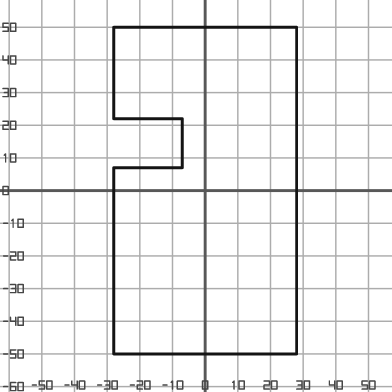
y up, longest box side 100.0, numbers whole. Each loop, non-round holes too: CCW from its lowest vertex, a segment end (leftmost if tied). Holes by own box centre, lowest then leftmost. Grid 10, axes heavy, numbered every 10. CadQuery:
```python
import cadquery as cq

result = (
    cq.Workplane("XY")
    .moveTo(-28.0, -50.0)
    .lineTo(28.0, -50.0)
    .lineTo(28.0, 50.0)
    .lineTo(-28.0, 50.0)
    .lineTo(-28.0, 22.0)
    .lineTo(-7.0, 22.0)
    .lineTo(-7.0, 7.0)
    .lineTo(-28.0, 7.0)
    .close()
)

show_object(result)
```